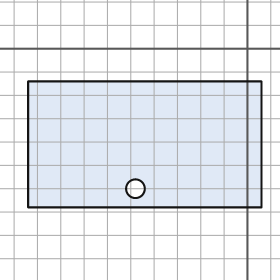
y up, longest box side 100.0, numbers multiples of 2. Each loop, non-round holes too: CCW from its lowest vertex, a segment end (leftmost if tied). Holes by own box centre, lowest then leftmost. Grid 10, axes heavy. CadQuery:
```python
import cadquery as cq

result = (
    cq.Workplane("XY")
    .moveTo(-94.0, -68.0)
    .lineTo(6.0, -68.0)
    .lineTo(6.0, -14.0)
    .lineTo(-94.0, -14.0)
    .close()
    .moveTo(-48.0, -60.0)
    .circle(4.0)
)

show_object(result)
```